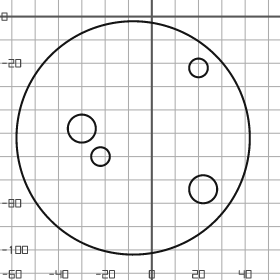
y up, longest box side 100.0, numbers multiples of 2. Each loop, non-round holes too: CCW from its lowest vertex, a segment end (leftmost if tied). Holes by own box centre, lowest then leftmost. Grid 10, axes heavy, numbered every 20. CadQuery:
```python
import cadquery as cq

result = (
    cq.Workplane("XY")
    .moveTo(-8.0, -52.0)
    .circle(50.0)
    .moveTo(22.0, -74.0)
    .circle(6.0)
    .moveTo(-22.0, -60.0)
    .circle(4.0)
    .moveTo(-30.0, -48.0)
    .circle(6.0)
    .moveTo(20.0, -22.0)
    .circle(4.0)
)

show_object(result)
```